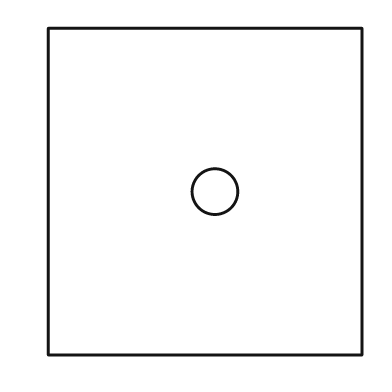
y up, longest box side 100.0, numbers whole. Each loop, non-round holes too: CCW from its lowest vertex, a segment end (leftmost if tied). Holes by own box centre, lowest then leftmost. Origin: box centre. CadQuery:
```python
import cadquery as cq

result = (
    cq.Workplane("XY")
    .moveTo(-48.0, -50.0)
    .lineTo(48.0, -50.0)
    .lineTo(48.0, 50.0)
    .lineTo(-48.0, 50.0)
    .close()
    .moveTo(3.0, 0.0)
    .circle(7.0)
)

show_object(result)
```